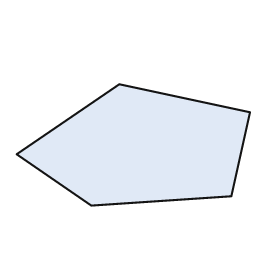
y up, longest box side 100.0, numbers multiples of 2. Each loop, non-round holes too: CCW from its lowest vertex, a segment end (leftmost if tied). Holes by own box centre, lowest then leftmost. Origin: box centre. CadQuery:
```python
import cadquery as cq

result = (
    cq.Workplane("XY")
    .moveTo(-18.0, -26.0)
    .lineTo(42.0, -22.0)
    .lineTo(50.0, 14.0)
    .lineTo(-6.0, 26.0)
    .lineTo(-50.0, -4.0)
    .close()
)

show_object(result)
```